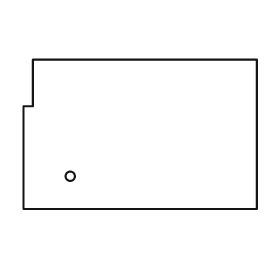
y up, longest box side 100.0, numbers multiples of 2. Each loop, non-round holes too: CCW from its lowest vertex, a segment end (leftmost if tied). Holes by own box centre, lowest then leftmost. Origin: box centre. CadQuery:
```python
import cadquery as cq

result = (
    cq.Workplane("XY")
    .moveTo(-50.0, -32.0)
    .lineTo(50.0, -32.0)
    .lineTo(50.0, 32.0)
    .lineTo(-46.0, 32.0)
    .lineTo(-46.0, 12.0)
    .lineTo(-50.0, 12.0)
    .close()
    .moveTo(-30.0, -18.0)
    .circle(2.0)
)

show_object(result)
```